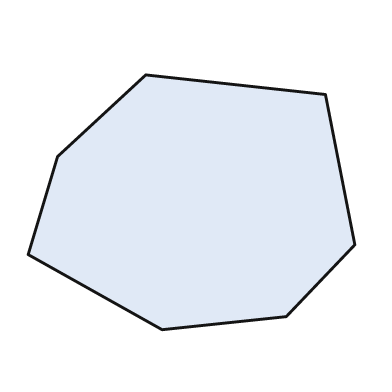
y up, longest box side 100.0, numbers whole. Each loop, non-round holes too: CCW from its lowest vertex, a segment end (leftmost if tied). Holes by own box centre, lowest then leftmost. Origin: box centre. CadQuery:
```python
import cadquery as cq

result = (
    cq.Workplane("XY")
    .moveTo(-9.0, -39.0)
    .lineTo(29.0, -35.0)
    .lineTo(50.0, -13.0)
    .lineTo(41.0, 33.0)
    .lineTo(-14.0, 39.0)
    .lineTo(-41.0, 14.0)
    .lineTo(-50.0, -16.0)
    .close()
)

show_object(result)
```